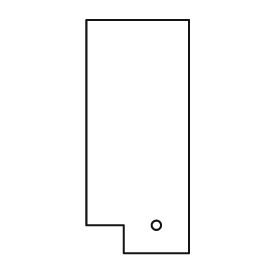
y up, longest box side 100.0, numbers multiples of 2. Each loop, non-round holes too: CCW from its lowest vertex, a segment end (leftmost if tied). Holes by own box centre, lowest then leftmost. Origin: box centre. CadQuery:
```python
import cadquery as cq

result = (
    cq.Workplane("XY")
    .moveTo(-6.0, -50.0)
    .lineTo(22.0, -50.0)
    .lineTo(22.0, 50.0)
    .lineTo(-22.0, 50.0)
    .lineTo(-22.0, -38.0)
    .lineTo(-6.0, -38.0)
    .close()
    .moveTo(8.0, -38.0)
    .circle(2.0)
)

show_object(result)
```